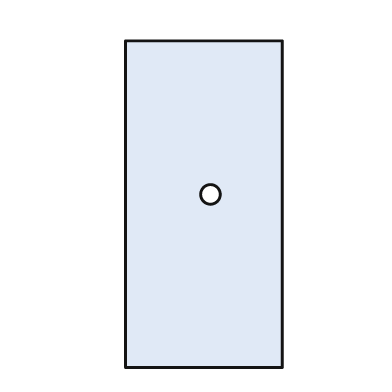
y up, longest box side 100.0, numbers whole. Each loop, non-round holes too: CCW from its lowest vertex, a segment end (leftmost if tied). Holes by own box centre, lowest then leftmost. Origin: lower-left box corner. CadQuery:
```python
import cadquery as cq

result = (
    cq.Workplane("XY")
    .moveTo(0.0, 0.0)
    .lineTo(48.0, 0.0)
    .lineTo(48.0, 100.0)
    .lineTo(0.0, 100.0)
    .close()
    .moveTo(26.0, 53.0)
    .circle(3.0)
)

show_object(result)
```